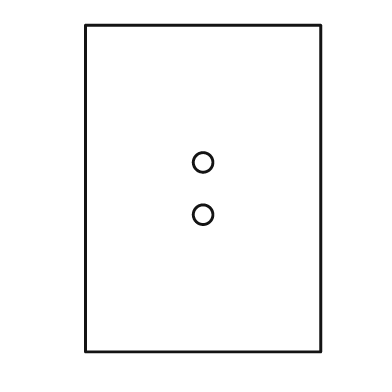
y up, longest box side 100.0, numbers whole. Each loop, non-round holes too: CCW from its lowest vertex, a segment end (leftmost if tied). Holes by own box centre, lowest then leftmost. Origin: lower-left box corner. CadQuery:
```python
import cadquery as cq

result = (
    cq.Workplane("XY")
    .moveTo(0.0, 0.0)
    .lineTo(72.0, 0.0)
    .lineTo(72.0, 100.0)
    .lineTo(0.0, 100.0)
    .close()
    .moveTo(36.0, 42.0)
    .circle(3.0)
    .moveTo(36.0, 58.0)
    .circle(3.0)
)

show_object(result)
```